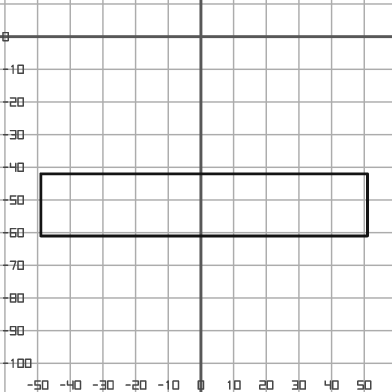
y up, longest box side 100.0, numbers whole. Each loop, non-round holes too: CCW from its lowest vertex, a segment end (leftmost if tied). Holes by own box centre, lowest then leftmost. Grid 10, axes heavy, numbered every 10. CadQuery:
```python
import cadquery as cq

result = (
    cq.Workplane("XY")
    .moveTo(-49.0, -61.0)
    .lineTo(51.0, -61.0)
    .lineTo(51.0, -42.0)
    .lineTo(-49.0, -42.0)
    .close()
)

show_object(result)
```